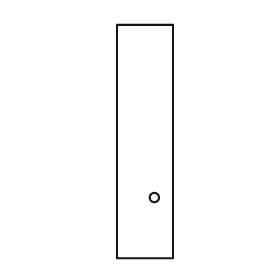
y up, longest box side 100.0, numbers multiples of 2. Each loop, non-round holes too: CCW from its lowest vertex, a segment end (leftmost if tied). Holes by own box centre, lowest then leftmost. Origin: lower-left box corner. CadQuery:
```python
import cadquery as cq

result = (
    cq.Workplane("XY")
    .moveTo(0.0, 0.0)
    .lineTo(24.0, 0.0)
    .lineTo(24.0, 100.0)
    .lineTo(0.0, 100.0)
    .close()
    .moveTo(16.0, 26.0)
    .circle(2.0)
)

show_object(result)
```